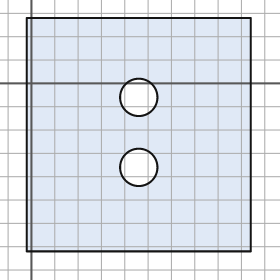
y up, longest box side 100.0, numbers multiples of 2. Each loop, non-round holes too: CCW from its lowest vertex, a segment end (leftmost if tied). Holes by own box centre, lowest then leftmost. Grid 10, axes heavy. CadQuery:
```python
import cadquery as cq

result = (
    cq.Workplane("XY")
    .moveTo(-2.0, -72.0)
    .lineTo(94.0, -72.0)
    .lineTo(94.0, 28.0)
    .lineTo(-2.0, 28.0)
    .close()
    .moveTo(46.0, -36.0)
    .circle(8.0)
    .moveTo(46.0, -6.0)
    .circle(8.0)
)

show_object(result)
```